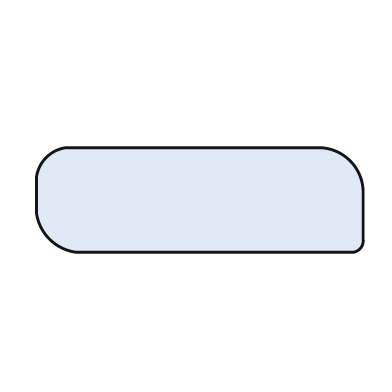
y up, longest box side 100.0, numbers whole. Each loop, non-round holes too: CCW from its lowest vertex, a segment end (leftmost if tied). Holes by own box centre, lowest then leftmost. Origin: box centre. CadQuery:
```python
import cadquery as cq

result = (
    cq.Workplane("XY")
    .moveTo(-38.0, -16.0)
    .lineTo(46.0, -16.0)
    .threePointArc((49.0, -15.0), (50.0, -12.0))
    .lineTo(50.0, 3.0)
    .threePointArc((46.0, 12.0), (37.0, 16.0))
    .lineTo(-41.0, 16.0)
    .threePointArc((-47.0, 13.0), (-50.0, 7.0))
    .lineTo(-50.0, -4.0)
    .threePointArc((-46.0, -12.0), (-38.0, -16.0))
    .close()
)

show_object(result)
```